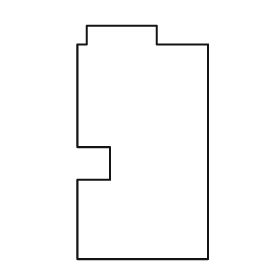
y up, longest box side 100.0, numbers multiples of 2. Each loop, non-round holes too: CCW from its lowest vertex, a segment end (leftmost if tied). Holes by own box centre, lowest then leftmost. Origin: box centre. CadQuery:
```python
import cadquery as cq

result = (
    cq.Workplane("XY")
    .moveTo(-28.0, -50.0)
    .lineTo(28.0, -50.0)
    .lineTo(28.0, 42.0)
    .lineTo(6.0, 42.0)
    .lineTo(6.0, 50.0)
    .lineTo(-24.0, 50.0)
    .lineTo(-24.0, 42.0)
    .lineTo(-28.0, 42.0)
    .lineTo(-28.0, -2.0)
    .lineTo(-14.0, -2.0)
    .lineTo(-14.0, -16.0)
    .lineTo(-28.0, -16.0)
    .close()
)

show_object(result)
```